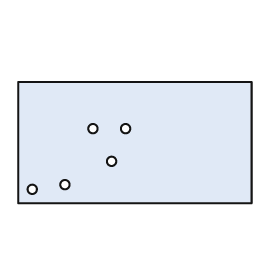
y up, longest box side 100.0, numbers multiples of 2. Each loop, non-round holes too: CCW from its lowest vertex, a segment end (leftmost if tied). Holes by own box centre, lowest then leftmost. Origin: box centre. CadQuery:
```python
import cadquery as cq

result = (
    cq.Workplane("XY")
    .moveTo(-50.0, -26.0)
    .lineTo(50.0, -26.0)
    .lineTo(50.0, 26.0)
    .lineTo(-50.0, 26.0)
    .close()
    .moveTo(-44.0, -20.0)
    .circle(2.0)
    .moveTo(-30.0, -18.0)
    .circle(2.0)
    .moveTo(-10.0, -8.0)
    .circle(2.0)
    .moveTo(-18.0, 6.0)
    .circle(2.0)
    .moveTo(-4.0, 6.0)
    .circle(2.0)
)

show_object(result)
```